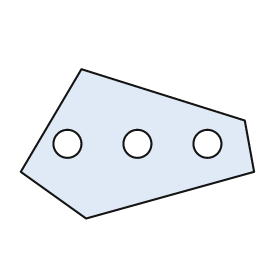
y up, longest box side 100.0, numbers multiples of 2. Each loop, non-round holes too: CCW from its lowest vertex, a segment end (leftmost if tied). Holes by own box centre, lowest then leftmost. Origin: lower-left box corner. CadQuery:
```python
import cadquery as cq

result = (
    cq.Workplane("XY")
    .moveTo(28.0, 0.0)
    .lineTo(100.0, 20.0)
    .lineTo(96.0, 42.0)
    .lineTo(26.0, 64.0)
    .lineTo(0.0, 20.0)
    .close()
    .moveTo(20.0, 32.0)
    .circle(6.0)
    .moveTo(50.0, 32.0)
    .circle(6.0)
    .moveTo(80.0, 32.0)
    .circle(6.0)
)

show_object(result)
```